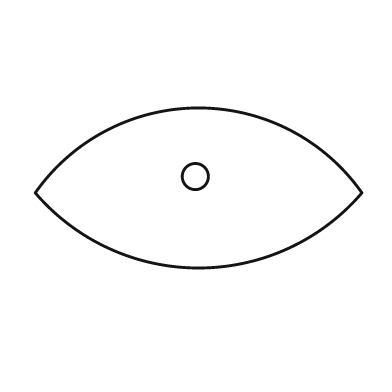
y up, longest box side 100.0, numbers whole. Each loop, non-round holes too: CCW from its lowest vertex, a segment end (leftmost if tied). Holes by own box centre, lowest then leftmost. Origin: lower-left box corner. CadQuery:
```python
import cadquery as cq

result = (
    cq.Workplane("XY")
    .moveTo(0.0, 23.0)
    .threePointArc((50.0, 0.0), (100.0, 23.0))
    .threePointArc((50.0, 49.0), (0.0, 23.0))
    .close()
    .moveTo(49.0, 28.0)
    .circle(4.0)
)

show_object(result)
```